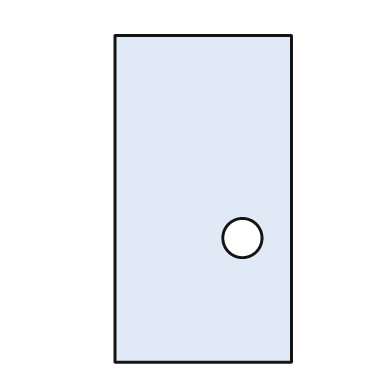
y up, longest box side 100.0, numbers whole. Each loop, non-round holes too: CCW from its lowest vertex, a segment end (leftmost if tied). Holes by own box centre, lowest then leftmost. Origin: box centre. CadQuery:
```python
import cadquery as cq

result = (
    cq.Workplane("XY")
    .moveTo(-27.0, -50.0)
    .lineTo(27.0, -50.0)
    .lineTo(27.0, 50.0)
    .lineTo(-27.0, 50.0)
    .close()
    .moveTo(12.0, -12.0)
    .circle(6.0)
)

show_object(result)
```